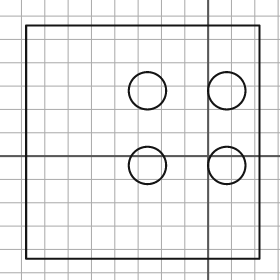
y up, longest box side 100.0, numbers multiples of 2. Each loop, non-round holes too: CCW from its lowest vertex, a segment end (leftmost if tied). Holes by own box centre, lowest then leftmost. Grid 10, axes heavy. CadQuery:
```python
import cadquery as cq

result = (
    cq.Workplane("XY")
    .moveTo(-78.0, -44.0)
    .lineTo(22.0, -44.0)
    .lineTo(22.0, 56.0)
    .lineTo(-78.0, 56.0)
    .close()
    .moveTo(-26.0, -4.0)
    .circle(8.0)
    .moveTo(8.0, -4.0)
    .circle(8.0)
    .moveTo(-26.0, 28.0)
    .circle(8.0)
    .moveTo(8.0, 28.0)
    .circle(8.0)
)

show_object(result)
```